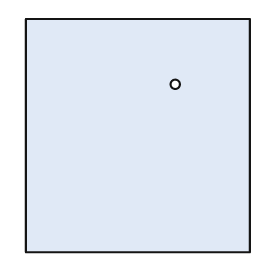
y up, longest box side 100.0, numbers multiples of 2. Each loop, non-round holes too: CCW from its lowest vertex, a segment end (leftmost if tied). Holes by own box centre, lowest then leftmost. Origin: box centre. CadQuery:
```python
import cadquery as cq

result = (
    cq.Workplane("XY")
    .moveTo(-48.0, -50.0)
    .lineTo(48.0, -50.0)
    .lineTo(48.0, 50.0)
    .lineTo(-48.0, 50.0)
    .close()
    .moveTo(16.0, 22.0)
    .circle(2.0)
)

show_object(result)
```